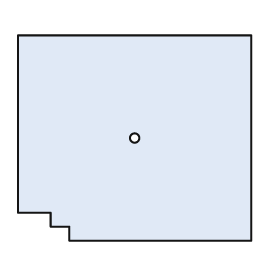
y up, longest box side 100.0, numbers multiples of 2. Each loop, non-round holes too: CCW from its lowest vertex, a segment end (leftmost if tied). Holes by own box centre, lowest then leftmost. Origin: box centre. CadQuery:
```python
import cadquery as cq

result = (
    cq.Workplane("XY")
    .moveTo(-28.0, -44.0)
    .lineTo(50.0, -44.0)
    .lineTo(50.0, 44.0)
    .lineTo(-50.0, 44.0)
    .lineTo(-50.0, -32.0)
    .lineTo(-36.0, -32.0)
    .lineTo(-36.0, -38.0)
    .lineTo(-28.0, -38.0)
    .close()
    .moveTo(0.0, 0.0)
    .circle(2.0)
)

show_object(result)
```